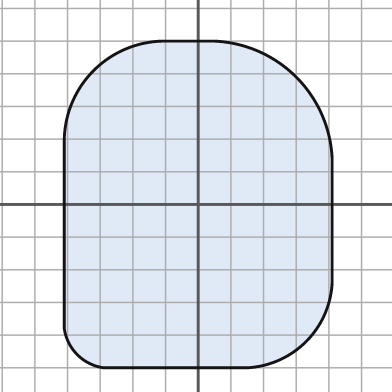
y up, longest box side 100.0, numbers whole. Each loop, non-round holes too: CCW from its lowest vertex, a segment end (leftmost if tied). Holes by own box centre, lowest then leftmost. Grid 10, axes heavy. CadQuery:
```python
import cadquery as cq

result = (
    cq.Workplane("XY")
    .moveTo(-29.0, -50.0)
    .lineTo(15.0, -50.0)
    .threePointArc((33.0, -42.0), (41.0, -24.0))
    .lineTo(41.0, 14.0)
    .threePointArc((30.0, 39.0), (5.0, 50.0))
    .lineTo(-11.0, 50.0)
    .threePointArc((-32.0, 41.0), (-41.0, 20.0))
    .lineTo(-41.0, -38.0)
    .threePointArc((-37.0, -46.0), (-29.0, -50.0))
    .close()
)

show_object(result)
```